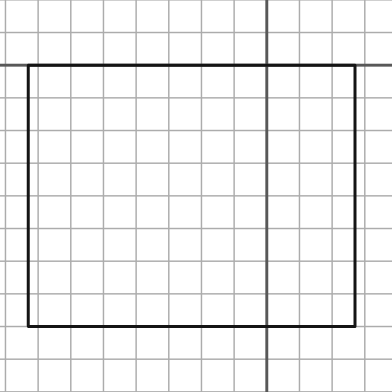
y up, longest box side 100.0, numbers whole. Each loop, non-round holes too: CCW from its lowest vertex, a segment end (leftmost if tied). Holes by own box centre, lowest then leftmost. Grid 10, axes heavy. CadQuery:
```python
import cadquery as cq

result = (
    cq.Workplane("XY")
    .moveTo(-73.0, -80.0)
    .lineTo(27.0, -80.0)
    .lineTo(27.0, 0.0)
    .lineTo(-73.0, 0.0)
    .close()
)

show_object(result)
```